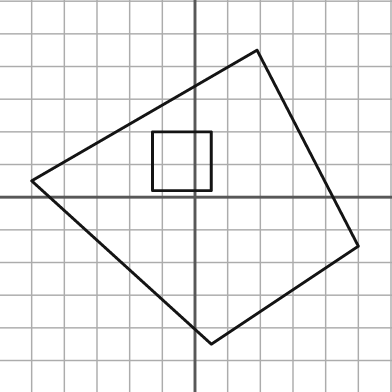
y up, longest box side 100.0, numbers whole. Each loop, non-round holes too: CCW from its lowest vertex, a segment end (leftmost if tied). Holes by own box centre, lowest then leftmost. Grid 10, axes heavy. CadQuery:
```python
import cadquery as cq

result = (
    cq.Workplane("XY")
    .moveTo(5.0, -45.0)
    .lineTo(50.0, -15.0)
    .lineTo(19.0, 45.0)
    .lineTo(-50.0, 5.0)
    .close()
    .moveTo(-13.0, 2.0)
    .lineTo(5.0, 2.0)
    .lineTo(5.0, 20.0)
    .lineTo(-13.0, 20.0)
    .close()
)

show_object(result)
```